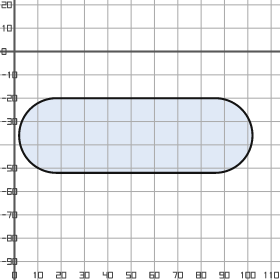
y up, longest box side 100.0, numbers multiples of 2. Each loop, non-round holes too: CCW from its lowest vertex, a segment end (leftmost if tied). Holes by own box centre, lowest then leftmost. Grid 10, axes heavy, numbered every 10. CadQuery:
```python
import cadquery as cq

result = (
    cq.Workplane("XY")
    .moveTo(18.0, -52.0)
    .lineTo(86.0, -52.0)
    .threePointArc((102.0, -36.0), (86.0, -20.0))
    .lineTo(18.0, -20.0)
    .threePointArc((2.0, -36.0), (18.0, -52.0))
    .close()
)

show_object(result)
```